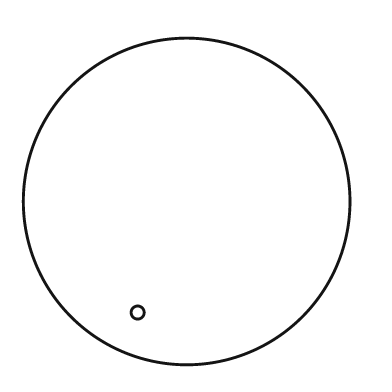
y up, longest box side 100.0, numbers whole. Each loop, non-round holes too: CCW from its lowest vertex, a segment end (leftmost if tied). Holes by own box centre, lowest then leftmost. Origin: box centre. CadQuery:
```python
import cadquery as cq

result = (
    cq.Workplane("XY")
    .moveTo(0.0, 0.0)
    .circle(50.0)
    .moveTo(-15.0, -34.0)
    .circle(2.0)
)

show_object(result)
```